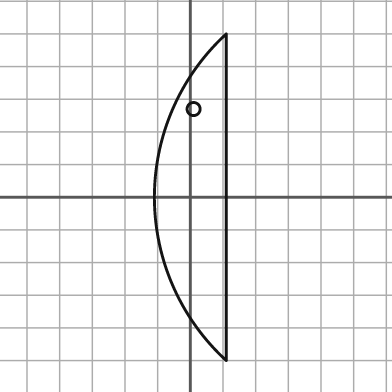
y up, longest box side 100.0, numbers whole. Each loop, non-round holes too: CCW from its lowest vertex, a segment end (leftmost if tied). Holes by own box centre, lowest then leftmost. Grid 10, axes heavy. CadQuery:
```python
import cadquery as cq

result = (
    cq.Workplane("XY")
    .moveTo(11.0, -50.0)
    .lineTo(11.0, 50.0)
    .threePointArc((-11.0, 0.0), (11.0, -50.0))
    .close()
    .moveTo(1.0, 27.0)
    .circle(2.0)
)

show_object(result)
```